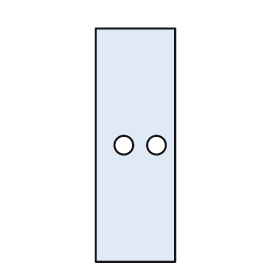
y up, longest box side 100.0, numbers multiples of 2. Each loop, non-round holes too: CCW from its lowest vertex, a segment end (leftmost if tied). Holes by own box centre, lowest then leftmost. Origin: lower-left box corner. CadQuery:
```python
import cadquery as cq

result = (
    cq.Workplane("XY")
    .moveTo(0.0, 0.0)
    .lineTo(34.0, 0.0)
    .lineTo(34.0, 100.0)
    .lineTo(0.0, 100.0)
    .close()
    .moveTo(12.0, 50.0)
    .circle(4.0)
    .moveTo(26.0, 50.0)
    .circle(4.0)
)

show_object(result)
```